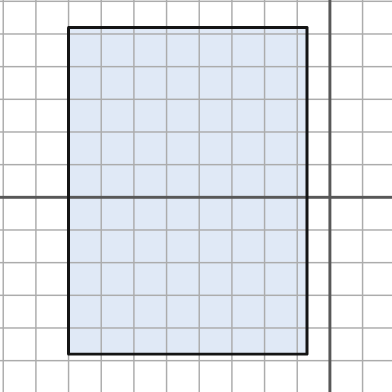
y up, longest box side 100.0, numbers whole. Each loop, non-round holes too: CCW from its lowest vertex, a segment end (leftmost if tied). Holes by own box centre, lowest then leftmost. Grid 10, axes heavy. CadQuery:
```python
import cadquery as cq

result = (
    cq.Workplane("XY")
    .moveTo(-80.0, -48.0)
    .lineTo(-7.0, -48.0)
    .lineTo(-7.0, 52.0)
    .lineTo(-80.0, 52.0)
    .close()
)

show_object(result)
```